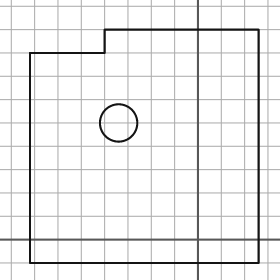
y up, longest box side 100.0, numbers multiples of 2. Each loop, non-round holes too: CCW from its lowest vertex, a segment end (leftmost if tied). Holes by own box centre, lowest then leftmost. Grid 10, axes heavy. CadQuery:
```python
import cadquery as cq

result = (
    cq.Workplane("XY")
    .moveTo(-72.0, -10.0)
    .lineTo(26.0, -10.0)
    .lineTo(26.0, 90.0)
    .lineTo(-40.0, 90.0)
    .lineTo(-40.0, 80.0)
    .lineTo(-72.0, 80.0)
    .close()
    .moveTo(-34.0, 50.0)
    .circle(8.0)
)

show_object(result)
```